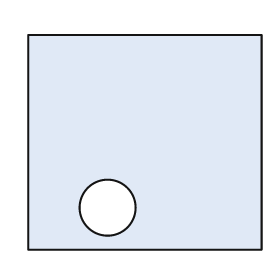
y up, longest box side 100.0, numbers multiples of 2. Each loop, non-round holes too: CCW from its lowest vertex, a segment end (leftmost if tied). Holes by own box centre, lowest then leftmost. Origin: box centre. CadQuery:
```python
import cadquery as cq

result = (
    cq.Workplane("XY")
    .moveTo(-50.0, -46.0)
    .lineTo(50.0, -46.0)
    .lineTo(50.0, 46.0)
    .lineTo(-50.0, 46.0)
    .close()
    .moveTo(-16.0, -28.0)
    .circle(12.0)
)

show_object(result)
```